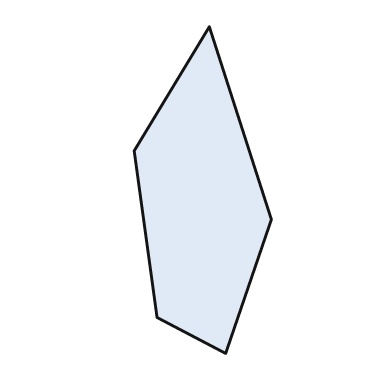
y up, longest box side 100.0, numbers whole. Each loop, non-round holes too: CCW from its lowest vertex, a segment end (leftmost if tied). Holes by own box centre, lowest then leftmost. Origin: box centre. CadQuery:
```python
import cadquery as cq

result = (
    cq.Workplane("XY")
    .moveTo(7.0, -50.0)
    .lineTo(21.0, -9.0)
    .lineTo(2.0, 50.0)
    .lineTo(-21.0, 12.0)
    .lineTo(-14.0, -39.0)
    .close()
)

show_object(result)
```